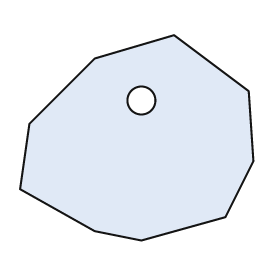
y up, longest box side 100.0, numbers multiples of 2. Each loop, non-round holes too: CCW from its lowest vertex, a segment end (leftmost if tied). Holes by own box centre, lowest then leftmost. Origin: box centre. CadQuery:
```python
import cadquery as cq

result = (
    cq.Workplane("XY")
    .moveTo(2.0, -44.0)
    .lineTo(38.0, -34.0)
    .lineTo(50.0, -10.0)
    .lineTo(48.0, 20.0)
    .lineTo(16.0, 44.0)
    .lineTo(-18.0, 34.0)
    .lineTo(-46.0, 6.0)
    .lineTo(-50.0, -22.0)
    .lineTo(-18.0, -40.0)
    .close()
    .moveTo(2.0, 16.0)
    .circle(6.0)
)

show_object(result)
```